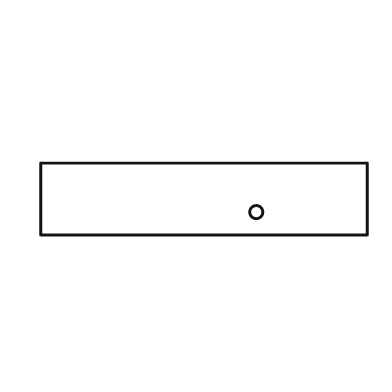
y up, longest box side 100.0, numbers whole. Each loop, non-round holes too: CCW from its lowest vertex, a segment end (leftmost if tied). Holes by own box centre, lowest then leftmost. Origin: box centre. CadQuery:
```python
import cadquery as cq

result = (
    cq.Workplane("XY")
    .moveTo(-50.0, -11.0)
    .lineTo(50.0, -11.0)
    .lineTo(50.0, 11.0)
    .lineTo(-50.0, 11.0)
    .close()
    .moveTo(16.0, -4.0)
    .circle(2.0)
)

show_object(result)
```